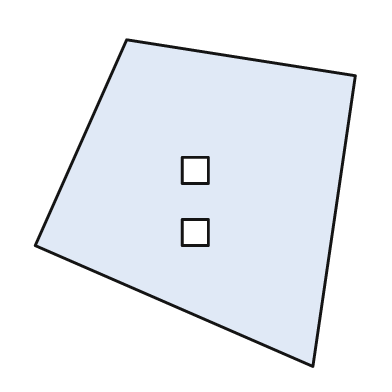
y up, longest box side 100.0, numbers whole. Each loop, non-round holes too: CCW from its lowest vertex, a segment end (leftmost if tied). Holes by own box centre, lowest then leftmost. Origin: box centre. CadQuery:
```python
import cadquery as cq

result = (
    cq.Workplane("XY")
    .moveTo(36.0, -50.0)
    .lineTo(49.0, 39.0)
    .lineTo(-21.0, 50.0)
    .lineTo(-49.0, -13.0)
    .close()
    .moveTo(-4.0, -13.0)
    .lineTo(4.0, -13.0)
    .lineTo(4.0, -5.0)
    .lineTo(-4.0, -5.0)
    .close()
    .moveTo(-4.0, 6.0)
    .lineTo(4.0, 6.0)
    .lineTo(4.0, 14.0)
    .lineTo(-4.0, 14.0)
    .close()
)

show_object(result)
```